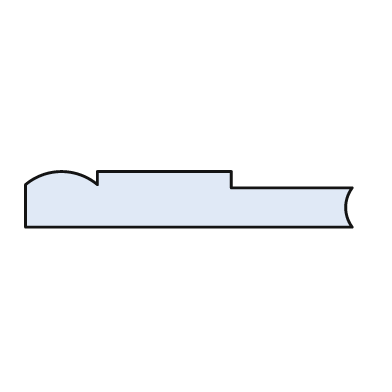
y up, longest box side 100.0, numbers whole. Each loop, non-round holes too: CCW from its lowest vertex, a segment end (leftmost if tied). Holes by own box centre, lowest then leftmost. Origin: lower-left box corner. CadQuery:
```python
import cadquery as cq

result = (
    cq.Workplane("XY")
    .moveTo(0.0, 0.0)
    .lineTo(100.0, 0.0)
    .threePointArc((98.0, 6.0), (100.0, 12.0))
    .lineTo(63.0, 12.0)
    .lineTo(63.0, 17.0)
    .lineTo(22.0, 17.0)
    .lineTo(22.0, 13.0)
    .threePointArc((11.0, 17.0), (0.0, 13.0))
    .close()
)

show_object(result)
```